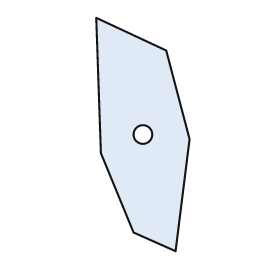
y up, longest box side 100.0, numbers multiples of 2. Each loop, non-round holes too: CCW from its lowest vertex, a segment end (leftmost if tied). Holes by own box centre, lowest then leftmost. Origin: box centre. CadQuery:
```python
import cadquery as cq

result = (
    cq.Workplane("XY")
    .moveTo(14.0, -50.0)
    .lineTo(20.0, -2.0)
    .lineTo(10.0, 36.0)
    .lineTo(-20.0, 50.0)
    .lineTo(-18.0, -8.0)
    .lineTo(-4.0, -42.0)
    .close()
    .moveTo(0.0, 0.0)
    .circle(4.0)
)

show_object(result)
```